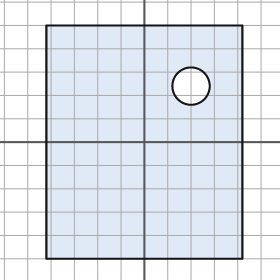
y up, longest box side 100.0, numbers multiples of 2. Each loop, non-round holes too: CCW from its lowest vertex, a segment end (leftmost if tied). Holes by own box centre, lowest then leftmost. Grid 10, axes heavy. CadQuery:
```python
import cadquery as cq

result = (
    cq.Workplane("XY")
    .moveTo(-42.0, -50.0)
    .lineTo(42.0, -50.0)
    .lineTo(42.0, 50.0)
    .lineTo(-42.0, 50.0)
    .close()
    .moveTo(20.0, 24.0)
    .circle(8.0)
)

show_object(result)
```